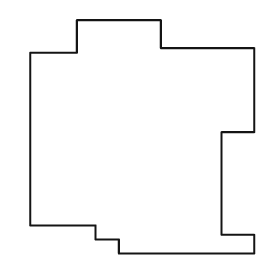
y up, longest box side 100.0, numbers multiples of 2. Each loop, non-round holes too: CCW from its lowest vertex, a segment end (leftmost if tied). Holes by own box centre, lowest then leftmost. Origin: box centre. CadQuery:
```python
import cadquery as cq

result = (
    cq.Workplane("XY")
    .moveTo(-10.0, -50.0)
    .lineTo(48.0, -50.0)
    .lineTo(48.0, -42.0)
    .lineTo(34.0, -42.0)
    .lineTo(34.0, 2.0)
    .lineTo(48.0, 2.0)
    .lineTo(48.0, 38.0)
    .lineTo(8.0, 38.0)
    .lineTo(8.0, 50.0)
    .lineTo(-28.0, 50.0)
    .lineTo(-28.0, 36.0)
    .lineTo(-48.0, 36.0)
    .lineTo(-48.0, -38.0)
    .lineTo(-20.0, -38.0)
    .lineTo(-20.0, -44.0)
    .lineTo(-10.0, -44.0)
    .close()
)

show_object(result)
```